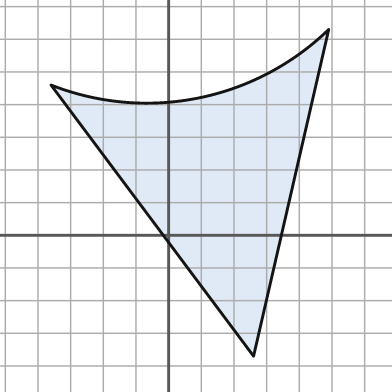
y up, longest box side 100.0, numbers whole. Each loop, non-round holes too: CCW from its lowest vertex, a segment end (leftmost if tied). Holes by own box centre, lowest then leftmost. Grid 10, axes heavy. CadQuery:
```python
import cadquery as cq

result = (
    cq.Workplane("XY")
    .moveTo(26.0, -37.0)
    .lineTo(49.0, 63.0)
    .threePointArc((9.0, 42.0), (-36.0, 46.0))
    .close()
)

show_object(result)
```